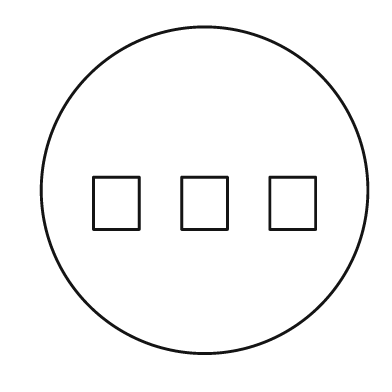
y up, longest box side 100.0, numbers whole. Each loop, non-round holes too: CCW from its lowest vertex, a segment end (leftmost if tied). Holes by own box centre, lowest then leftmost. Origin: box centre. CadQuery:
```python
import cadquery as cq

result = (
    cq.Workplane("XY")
    .moveTo(0.0, 0.0)
    .circle(50.0)
    .moveTo(-34.0, -12.0)
    .lineTo(-20.0, -12.0)
    .lineTo(-20.0, 4.0)
    .lineTo(-34.0, 4.0)
    .close()
    .moveTo(-7.0, -12.0)
    .lineTo(7.0, -12.0)
    .lineTo(7.0, 4.0)
    .lineTo(-7.0, 4.0)
    .close()
    .moveTo(20.0, -12.0)
    .lineTo(34.0, -12.0)
    .lineTo(34.0, 4.0)
    .lineTo(20.0, 4.0)
    .close()
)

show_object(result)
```